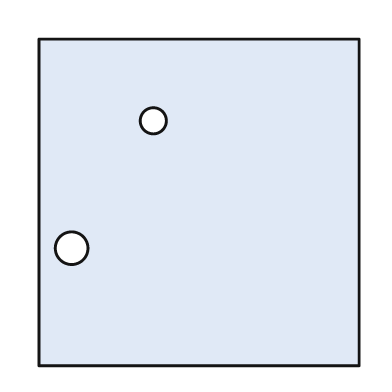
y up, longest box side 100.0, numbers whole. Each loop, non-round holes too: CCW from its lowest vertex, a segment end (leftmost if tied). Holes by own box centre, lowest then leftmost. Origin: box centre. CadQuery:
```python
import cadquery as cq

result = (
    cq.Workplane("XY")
    .moveTo(-49.0, -50.0)
    .lineTo(49.0, -50.0)
    .lineTo(49.0, 50.0)
    .lineTo(-49.0, 50.0)
    .close()
    .moveTo(-39.0, -14.0)
    .circle(5.0)
    .moveTo(-14.0, 25.0)
    .circle(4.0)
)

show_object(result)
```